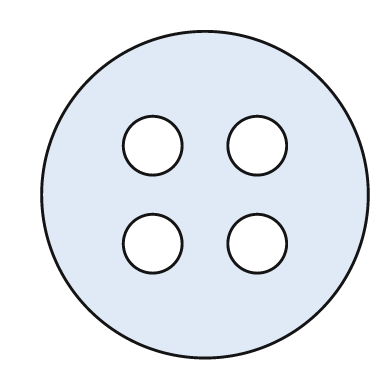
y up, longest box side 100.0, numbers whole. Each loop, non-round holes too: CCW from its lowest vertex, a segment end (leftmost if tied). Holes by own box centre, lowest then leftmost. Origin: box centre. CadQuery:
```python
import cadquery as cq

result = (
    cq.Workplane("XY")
    .moveTo(0.0, 0.0)
    .circle(50.0)
    .moveTo(-16.0, -15.0)
    .circle(9.0)
    .moveTo(16.0, -15.0)
    .circle(9.0)
    .moveTo(-16.0, 15.0)
    .circle(9.0)
    .moveTo(16.0, 15.0)
    .circle(9.0)
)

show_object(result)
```